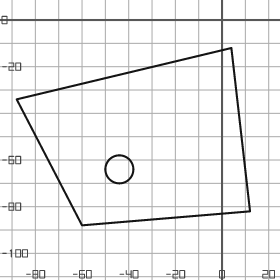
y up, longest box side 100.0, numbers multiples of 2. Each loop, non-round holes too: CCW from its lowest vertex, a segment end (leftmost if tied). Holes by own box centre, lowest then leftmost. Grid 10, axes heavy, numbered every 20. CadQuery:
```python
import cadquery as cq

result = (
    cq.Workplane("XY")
    .moveTo(-60.0, -88.0)
    .lineTo(12.0, -82.0)
    .lineTo(4.0, -12.0)
    .lineTo(-88.0, -34.0)
    .close()
    .moveTo(-44.0, -64.0)
    .circle(6.0)
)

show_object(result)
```